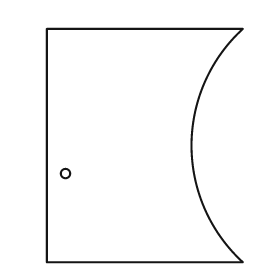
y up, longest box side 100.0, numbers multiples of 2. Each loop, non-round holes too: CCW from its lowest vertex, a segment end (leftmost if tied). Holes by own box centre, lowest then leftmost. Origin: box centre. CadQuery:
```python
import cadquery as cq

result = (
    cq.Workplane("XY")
    .moveTo(-42.0, -50.0)
    .lineTo(42.0, -50.0)
    .threePointArc((20.0, 0.0), (42.0, 50.0))
    .lineTo(-42.0, 50.0)
    .close()
    .moveTo(-34.0, -12.0)
    .circle(2.0)
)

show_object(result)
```